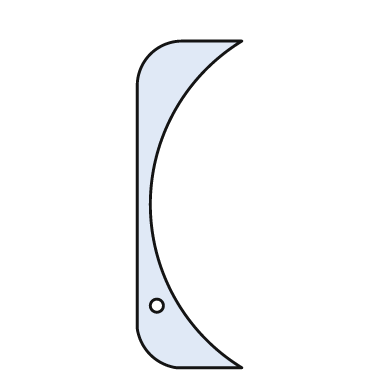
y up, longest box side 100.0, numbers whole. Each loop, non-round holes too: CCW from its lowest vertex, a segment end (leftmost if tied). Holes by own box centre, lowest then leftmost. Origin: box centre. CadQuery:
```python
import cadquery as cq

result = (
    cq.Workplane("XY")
    .moveTo(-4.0, -50.0)
    .lineTo(16.0, -50.0)
    .threePointArc((-12.0, 0.0), (16.0, 50.0))
    .lineTo(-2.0, 50.0)
    .threePointArc((-12.0, 46.0), (-16.0, 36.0))
    .lineTo(-16.0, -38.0)
    .threePointArc((-12.0, -46.0), (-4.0, -50.0))
    .close()
    .moveTo(-10.0, -31.0)
    .circle(2.0)
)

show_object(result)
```